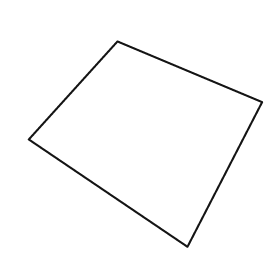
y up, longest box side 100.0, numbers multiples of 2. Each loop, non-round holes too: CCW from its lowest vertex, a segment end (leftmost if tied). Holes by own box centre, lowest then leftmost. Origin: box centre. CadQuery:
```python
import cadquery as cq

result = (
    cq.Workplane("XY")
    .moveTo(18.0, -44.0)
    .lineTo(50.0, 18.0)
    .lineTo(-12.0, 44.0)
    .lineTo(-50.0, 2.0)
    .close()
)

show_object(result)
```